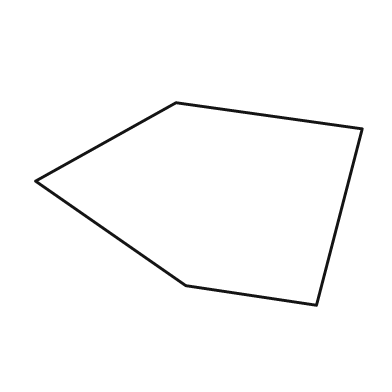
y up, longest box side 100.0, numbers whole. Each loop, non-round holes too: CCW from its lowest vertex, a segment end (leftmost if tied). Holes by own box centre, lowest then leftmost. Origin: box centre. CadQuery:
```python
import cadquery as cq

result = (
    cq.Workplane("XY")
    .moveTo(36.0, -31.0)
    .lineTo(50.0, 23.0)
    .lineTo(-7.0, 31.0)
    .lineTo(-50.0, 7.0)
    .lineTo(-4.0, -25.0)
    .close()
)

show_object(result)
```